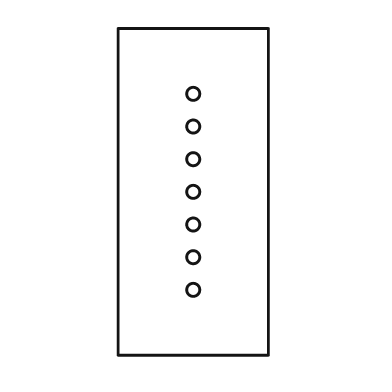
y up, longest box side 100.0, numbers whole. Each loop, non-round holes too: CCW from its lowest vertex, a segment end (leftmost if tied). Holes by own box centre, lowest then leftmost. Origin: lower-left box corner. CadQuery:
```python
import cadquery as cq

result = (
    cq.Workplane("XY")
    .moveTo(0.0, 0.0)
    .lineTo(46.0, 0.0)
    .lineTo(46.0, 100.0)
    .lineTo(0.0, 100.0)
    .close()
    .moveTo(23.0, 20.0)
    .circle(2.0)
    .moveTo(23.0, 30.0)
    .circle(2.0)
    .moveTo(23.0, 40.0)
    .circle(2.0)
    .moveTo(23.0, 50.0)
    .circle(2.0)
    .moveTo(23.0, 60.0)
    .circle(2.0)
    .moveTo(23.0, 70.0)
    .circle(2.0)
    .moveTo(23.0, 80.0)
    .circle(2.0)
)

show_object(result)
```